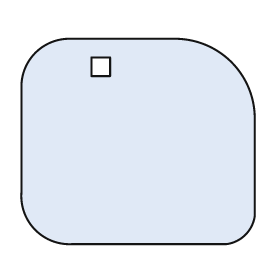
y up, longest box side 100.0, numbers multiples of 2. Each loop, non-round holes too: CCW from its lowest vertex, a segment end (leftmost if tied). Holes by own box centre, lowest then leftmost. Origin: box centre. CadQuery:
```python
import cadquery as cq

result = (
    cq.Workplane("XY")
    .moveTo(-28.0, -44.0)
    .lineTo(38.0, -44.0)
    .threePointArc((46.0, -40.0), (50.0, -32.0))
    .lineTo(50.0, 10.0)
    .threePointArc((40.0, 34.0), (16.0, 44.0))
    .lineTo(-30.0, 44.0)
    .threePointArc((-44.0, 38.0), (-50.0, 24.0))
    .lineTo(-50.0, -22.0)
    .threePointArc((-44.0, -38.0), (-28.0, -44.0))
    .close()
    .moveTo(-20.0, 28.0)
    .lineTo(-12.0, 28.0)
    .lineTo(-12.0, 36.0)
    .lineTo(-20.0, 36.0)
    .close()
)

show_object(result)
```